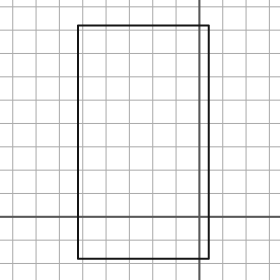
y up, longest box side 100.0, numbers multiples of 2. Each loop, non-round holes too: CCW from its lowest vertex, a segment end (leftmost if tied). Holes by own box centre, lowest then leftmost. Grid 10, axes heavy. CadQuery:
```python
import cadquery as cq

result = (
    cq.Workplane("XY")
    .moveTo(-52.0, -18.0)
    .lineTo(4.0, -18.0)
    .lineTo(4.0, 82.0)
    .lineTo(-52.0, 82.0)
    .close()
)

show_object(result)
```